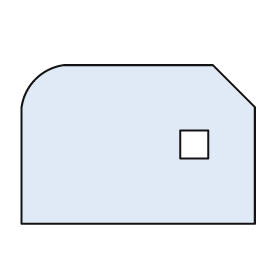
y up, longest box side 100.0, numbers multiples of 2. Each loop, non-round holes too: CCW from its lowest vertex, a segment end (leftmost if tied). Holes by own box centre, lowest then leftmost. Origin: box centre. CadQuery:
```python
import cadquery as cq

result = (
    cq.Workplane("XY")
    .moveTo(-50.0, -34.0)
    .lineTo(50.0, -34.0)
    .lineTo(50.0, 16.0)
    .lineTo(32.0, 34.0)
    .lineTo(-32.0, 34.0)
    .threePointArc((-44.0, 28.0), (-50.0, 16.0))
    .close()
    .moveTo(18.0, -6.0)
    .lineTo(30.0, -6.0)
    .lineTo(30.0, 6.0)
    .lineTo(18.0, 6.0)
    .close()
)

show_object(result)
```